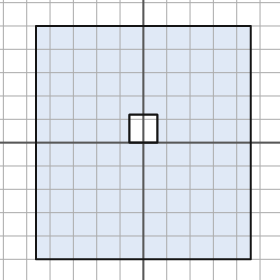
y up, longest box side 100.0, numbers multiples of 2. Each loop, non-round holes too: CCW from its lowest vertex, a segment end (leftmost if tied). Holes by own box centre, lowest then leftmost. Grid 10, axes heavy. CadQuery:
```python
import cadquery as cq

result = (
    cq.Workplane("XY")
    .moveTo(-46.0, -50.0)
    .lineTo(46.0, -50.0)
    .lineTo(46.0, 50.0)
    .lineTo(-46.0, 50.0)
    .close()
    .moveTo(-6.0, 0.0)
    .lineTo(6.0, 0.0)
    .lineTo(6.0, 12.0)
    .lineTo(-6.0, 12.0)
    .close()
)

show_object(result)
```